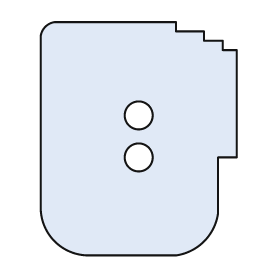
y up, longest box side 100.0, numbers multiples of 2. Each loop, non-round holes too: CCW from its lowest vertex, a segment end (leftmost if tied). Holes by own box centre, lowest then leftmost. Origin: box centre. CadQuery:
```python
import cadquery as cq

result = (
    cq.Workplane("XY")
    .moveTo(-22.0, -50.0)
    .lineTo(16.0, -50.0)
    .threePointArc((28.0, -44.0), (34.0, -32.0))
    .lineTo(34.0, -8.0)
    .lineTo(42.0, -8.0)
    .lineTo(42.0, 38.0)
    .lineTo(36.0, 38.0)
    .lineTo(36.0, 42.0)
    .lineTo(28.0, 42.0)
    .lineTo(28.0, 46.0)
    .lineTo(16.0, 46.0)
    .lineTo(16.0, 50.0)
    .lineTo(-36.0, 50.0)
    .threePointArc((-40.0, 48.0), (-42.0, 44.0))
    .lineTo(-42.0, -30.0)
    .threePointArc((-36.0, -44.0), (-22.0, -50.0))
    .close()
    .moveTo(0.0, -8.0)
    .circle(6.0)
    .moveTo(0.0, 10.0)
    .circle(6.0)
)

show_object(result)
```